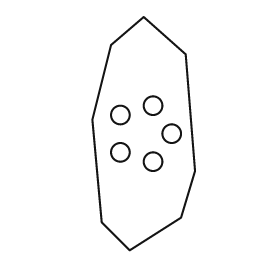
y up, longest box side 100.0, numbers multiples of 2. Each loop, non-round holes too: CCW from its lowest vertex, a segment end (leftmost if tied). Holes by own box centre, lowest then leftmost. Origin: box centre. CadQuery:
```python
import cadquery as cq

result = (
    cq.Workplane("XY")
    .moveTo(-6.0, -50.0)
    .lineTo(16.0, -36.0)
    .lineTo(22.0, -16.0)
    .lineTo(18.0, 34.0)
    .lineTo(0.0, 50.0)
    .lineTo(-14.0, 38.0)
    .lineTo(-22.0, 6.0)
    .lineTo(-18.0, -38.0)
    .close()
    .moveTo(4.0, -12.0)
    .circle(4.0)
    .moveTo(-10.0, -8.0)
    .circle(4.0)
    .moveTo(12.0, 0.0)
    .circle(4.0)
    .moveTo(-10.0, 8.0)
    .circle(4.0)
    .moveTo(4.0, 12.0)
    .circle(4.0)
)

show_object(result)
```